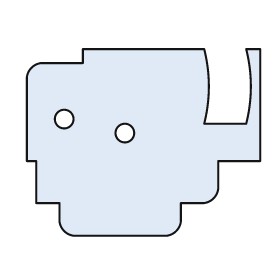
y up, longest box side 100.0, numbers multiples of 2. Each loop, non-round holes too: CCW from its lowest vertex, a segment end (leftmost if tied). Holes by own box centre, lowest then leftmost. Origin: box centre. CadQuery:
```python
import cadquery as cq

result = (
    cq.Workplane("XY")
    .moveTo(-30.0, -40.0)
    .lineTo(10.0, -40.0)
    .threePointArc((14.0, -38.0), (16.0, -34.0))
    .lineTo(16.0, -26.0)
    .lineTo(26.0, -26.0)
    .threePointArc((30.0, -24.0), (32.0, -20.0))
    .lineTo(32.0, -8.0)
    .lineTo(50.0, -8.0)
    .lineTo(50.0, 40.0)
    .lineTo(44.0, 40.0)
    .threePointArc((46.0, 24.0), (44.0, 8.0))
    .lineTo(26.0, 8.0)
    .threePointArc((28.0, 24.0), (26.0, 40.0))
    .lineTo(-26.0, 40.0)
    .lineTo(-26.0, 34.0)
    .lineTo(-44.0, 34.0)
    .threePointArc((-48.0, 32.0), (-50.0, 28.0))
    .lineTo(-50.0, -8.0)
    .lineTo(-46.0, -8.0)
    .lineTo(-46.0, -26.0)
    .lineTo(-36.0, -26.0)
    .lineTo(-36.0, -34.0)
    .threePointArc((-34.0, -38.0), (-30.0, -40.0))
    .close()
    .moveTo(-8.0, 4.0)
    .circle(4.0)
    .moveTo(-34.0, 10.0)
    .circle(4.0)
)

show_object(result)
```